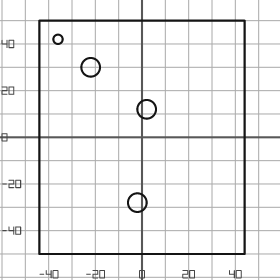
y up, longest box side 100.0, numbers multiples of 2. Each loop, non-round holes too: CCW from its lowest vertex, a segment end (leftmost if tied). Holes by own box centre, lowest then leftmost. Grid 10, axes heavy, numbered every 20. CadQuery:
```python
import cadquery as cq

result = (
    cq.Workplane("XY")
    .moveTo(-44.0, -50.0)
    .lineTo(44.0, -50.0)
    .lineTo(44.0, 50.0)
    .lineTo(-44.0, 50.0)
    .close()
    .moveTo(-2.0, -28.0)
    .circle(4.0)
    .moveTo(2.0, 12.0)
    .circle(4.0)
    .moveTo(-22.0, 30.0)
    .circle(4.0)
    .moveTo(-36.0, 42.0)
    .circle(2.0)
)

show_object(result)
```